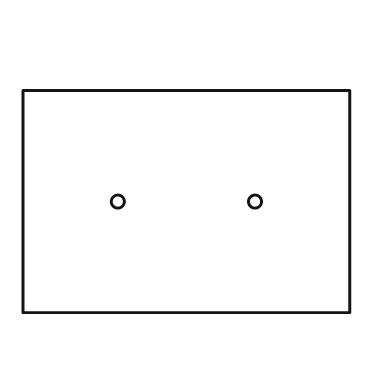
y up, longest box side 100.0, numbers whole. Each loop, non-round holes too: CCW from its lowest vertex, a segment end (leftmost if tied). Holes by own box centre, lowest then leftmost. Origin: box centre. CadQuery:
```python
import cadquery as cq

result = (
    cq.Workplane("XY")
    .moveTo(-50.0, -34.0)
    .lineTo(50.0, -34.0)
    .lineTo(50.0, 34.0)
    .lineTo(-50.0, 34.0)
    .close()
    .moveTo(-21.0, 0.0)
    .circle(2.0)
    .moveTo(21.0, 0.0)
    .circle(2.0)
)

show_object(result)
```